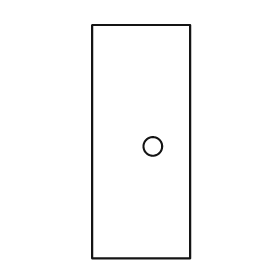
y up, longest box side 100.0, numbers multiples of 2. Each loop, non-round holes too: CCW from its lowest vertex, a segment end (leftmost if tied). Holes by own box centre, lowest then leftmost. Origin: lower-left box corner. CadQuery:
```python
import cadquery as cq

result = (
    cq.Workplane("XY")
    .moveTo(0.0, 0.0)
    .lineTo(42.0, 0.0)
    .lineTo(42.0, 100.0)
    .lineTo(0.0, 100.0)
    .close()
    .moveTo(26.0, 48.0)
    .circle(4.0)
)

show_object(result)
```